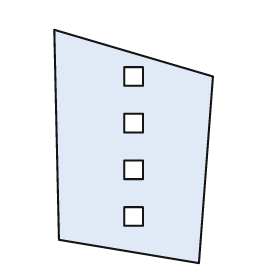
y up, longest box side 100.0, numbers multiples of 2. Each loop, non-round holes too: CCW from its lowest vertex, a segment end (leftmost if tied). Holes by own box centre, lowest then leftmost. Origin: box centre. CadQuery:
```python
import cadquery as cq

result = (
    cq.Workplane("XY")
    .moveTo(28.0, -50.0)
    .lineTo(34.0, 30.0)
    .lineTo(-34.0, 50.0)
    .lineTo(-32.0, -40.0)
    .close()
    .moveTo(-4.0, -34.0)
    .lineTo(4.0, -34.0)
    .lineTo(4.0, -26.0)
    .lineTo(-4.0, -26.0)
    .close()
    .moveTo(-4.0, -14.0)
    .lineTo(4.0, -14.0)
    .lineTo(4.0, -6.0)
    .lineTo(-4.0, -6.0)
    .close()
    .moveTo(-4.0, 6.0)
    .lineTo(4.0, 6.0)
    .lineTo(4.0, 14.0)
    .lineTo(-4.0, 14.0)
    .close()
    .moveTo(-4.0, 26.0)
    .lineTo(4.0, 26.0)
    .lineTo(4.0, 34.0)
    .lineTo(-4.0, 34.0)
    .close()
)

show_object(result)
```